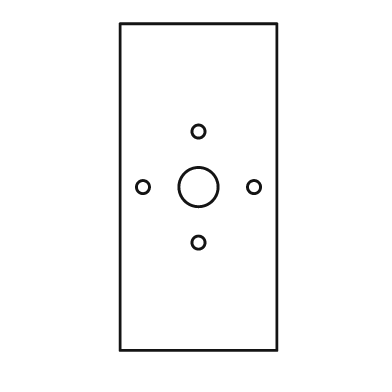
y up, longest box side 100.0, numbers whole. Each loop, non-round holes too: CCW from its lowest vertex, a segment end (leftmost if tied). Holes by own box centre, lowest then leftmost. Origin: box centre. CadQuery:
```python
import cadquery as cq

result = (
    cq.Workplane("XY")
    .moveTo(-24.0, -50.0)
    .lineTo(24.0, -50.0)
    .lineTo(24.0, 50.0)
    .lineTo(-24.0, 50.0)
    .close()
    .moveTo(0.0, -17.0)
    .circle(2.0)
    .moveTo(-17.0, 0.0)
    .circle(2.0)
    .moveTo(0.0, 0.0)
    .circle(6.0)
    .moveTo(17.0, 0.0)
    .circle(2.0)
    .moveTo(0.0, 17.0)
    .circle(2.0)
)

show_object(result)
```